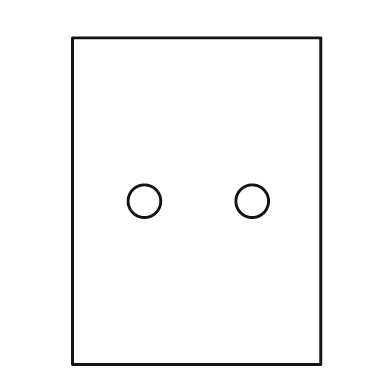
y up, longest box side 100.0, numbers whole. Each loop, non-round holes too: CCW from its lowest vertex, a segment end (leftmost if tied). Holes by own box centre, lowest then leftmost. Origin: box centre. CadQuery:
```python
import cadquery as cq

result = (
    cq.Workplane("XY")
    .moveTo(-38.0, -50.0)
    .lineTo(38.0, -50.0)
    .lineTo(38.0, 50.0)
    .lineTo(-38.0, 50.0)
    .close()
    .moveTo(-16.0, 0.0)
    .circle(5.0)
    .moveTo(17.0, 0.0)
    .circle(5.0)
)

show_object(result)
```